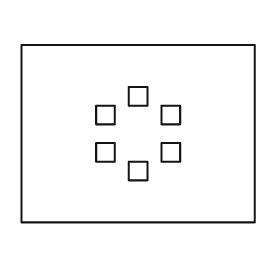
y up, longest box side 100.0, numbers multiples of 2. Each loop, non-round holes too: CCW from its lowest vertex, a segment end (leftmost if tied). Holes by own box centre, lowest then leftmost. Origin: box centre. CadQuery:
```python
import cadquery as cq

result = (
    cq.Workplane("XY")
    .moveTo(-50.0, -38.0)
    .lineTo(50.0, -38.0)
    .lineTo(50.0, 38.0)
    .lineTo(-50.0, 38.0)
    .close()
    .moveTo(-4.0, -20.0)
    .lineTo(4.0, -20.0)
    .lineTo(4.0, -12.0)
    .lineTo(-4.0, -12.0)
    .close()
    .moveTo(-18.0, -12.0)
    .lineTo(-10.0, -12.0)
    .lineTo(-10.0, -4.0)
    .lineTo(-18.0, -4.0)
    .close()
    .moveTo(10.0, -12.0)
    .lineTo(18.0, -12.0)
    .lineTo(18.0, -4.0)
    .lineTo(10.0, -4.0)
    .close()
    .moveTo(-18.0, 4.0)
    .lineTo(-10.0, 4.0)
    .lineTo(-10.0, 12.0)
    .lineTo(-18.0, 12.0)
    .close()
    .moveTo(10.0, 4.0)
    .lineTo(18.0, 4.0)
    .lineTo(18.0, 12.0)
    .lineTo(10.0, 12.0)
    .close()
    .moveTo(-4.0, 12.0)
    .lineTo(4.0, 12.0)
    .lineTo(4.0, 20.0)
    .lineTo(-4.0, 20.0)
    .close()
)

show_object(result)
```